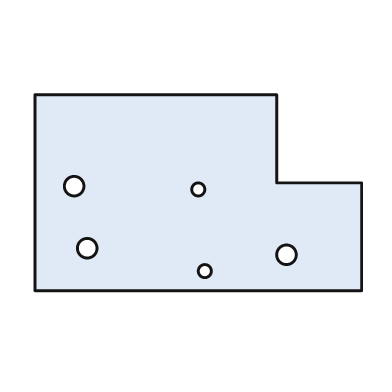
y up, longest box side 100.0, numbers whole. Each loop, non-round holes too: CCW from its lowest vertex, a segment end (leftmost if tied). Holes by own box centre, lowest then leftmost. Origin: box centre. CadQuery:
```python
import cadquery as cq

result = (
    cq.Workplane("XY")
    .moveTo(-50.0, -30.0)
    .lineTo(50.0, -30.0)
    .lineTo(50.0, 3.0)
    .lineTo(24.0, 3.0)
    .lineTo(24.0, 30.0)
    .lineTo(-50.0, 30.0)
    .close()
    .moveTo(2.0, -24.0)
    .circle(2.0)
    .moveTo(27.0, -19.0)
    .circle(3.0)
    .moveTo(-34.0, -17.0)
    .circle(3.0)
    .moveTo(0.0, 1.0)
    .circle(2.0)
    .moveTo(-38.0, 2.0)
    .circle(3.0)
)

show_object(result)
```